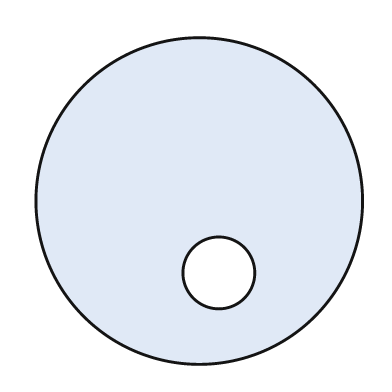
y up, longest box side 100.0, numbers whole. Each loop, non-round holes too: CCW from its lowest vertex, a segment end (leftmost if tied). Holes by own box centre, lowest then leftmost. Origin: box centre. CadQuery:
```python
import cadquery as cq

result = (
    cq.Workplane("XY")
    .moveTo(0.0, 0.0)
    .circle(50.0)
    .moveTo(6.0, -22.0)
    .circle(11.0)
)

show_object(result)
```